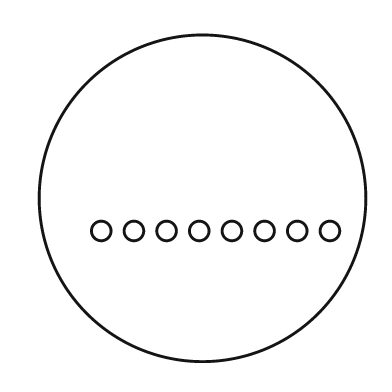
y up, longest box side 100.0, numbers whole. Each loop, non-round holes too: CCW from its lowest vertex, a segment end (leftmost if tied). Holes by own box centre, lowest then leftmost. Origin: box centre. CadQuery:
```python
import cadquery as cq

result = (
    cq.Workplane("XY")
    .moveTo(0.0, 0.0)
    .circle(50.0)
    .moveTo(-31.0, -10.0)
    .circle(3.0)
    .moveTo(-21.0, -10.0)
    .circle(3.0)
    .moveTo(-11.0, -10.0)
    .circle(3.0)
    .moveTo(-1.0, -10.0)
    .circle(3.0)
    .moveTo(9.0, -10.0)
    .circle(3.0)
    .moveTo(19.0, -10.0)
    .circle(3.0)
    .moveTo(29.0, -10.0)
    .circle(3.0)
    .moveTo(39.0, -10.0)
    .circle(3.0)
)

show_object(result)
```